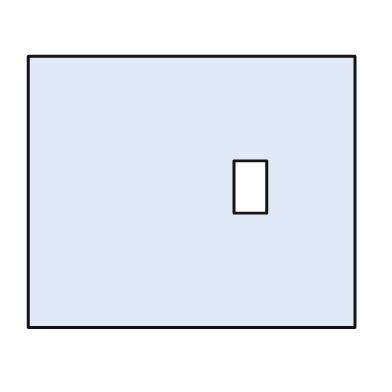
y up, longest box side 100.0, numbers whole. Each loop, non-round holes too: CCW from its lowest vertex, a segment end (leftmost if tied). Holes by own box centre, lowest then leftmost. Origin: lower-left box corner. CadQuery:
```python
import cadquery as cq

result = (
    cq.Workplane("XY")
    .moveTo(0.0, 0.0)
    .lineTo(100.0, 0.0)
    .lineTo(100.0, 83.0)
    .lineTo(0.0, 83.0)
    .close()
    .moveTo(63.0, 35.0)
    .lineTo(73.0, 35.0)
    .lineTo(73.0, 51.0)
    .lineTo(63.0, 51.0)
    .close()
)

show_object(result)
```